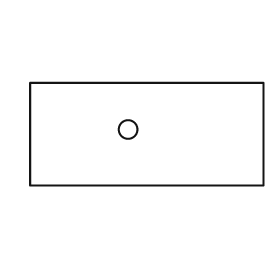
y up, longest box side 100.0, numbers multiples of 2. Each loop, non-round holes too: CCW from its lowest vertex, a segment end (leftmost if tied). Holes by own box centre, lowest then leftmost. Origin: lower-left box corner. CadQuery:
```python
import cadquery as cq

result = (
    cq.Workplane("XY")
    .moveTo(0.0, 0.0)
    .lineTo(100.0, 0.0)
    .lineTo(100.0, 44.0)
    .lineTo(0.0, 44.0)
    .close()
    .moveTo(42.0, 24.0)
    .circle(4.0)
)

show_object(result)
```